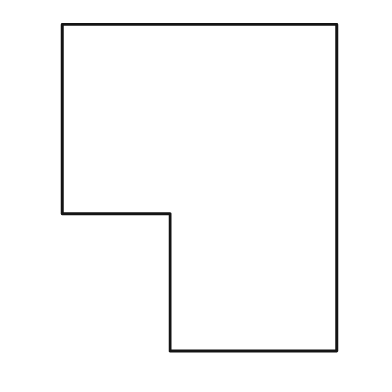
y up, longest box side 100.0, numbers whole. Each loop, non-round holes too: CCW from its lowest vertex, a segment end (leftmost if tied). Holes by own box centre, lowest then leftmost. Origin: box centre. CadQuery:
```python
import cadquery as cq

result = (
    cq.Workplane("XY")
    .moveTo(-9.0, -50.0)
    .lineTo(42.0, -50.0)
    .lineTo(42.0, 50.0)
    .lineTo(-42.0, 50.0)
    .lineTo(-42.0, -8.0)
    .lineTo(-9.0, -8.0)
    .close()
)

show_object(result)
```